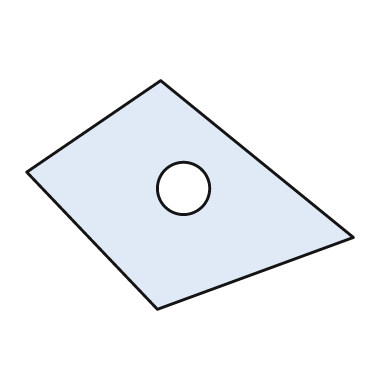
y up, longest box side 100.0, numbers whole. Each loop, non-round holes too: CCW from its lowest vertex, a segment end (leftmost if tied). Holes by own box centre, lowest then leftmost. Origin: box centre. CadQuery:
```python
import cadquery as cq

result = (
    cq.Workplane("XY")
    .moveTo(-10.0, -35.0)
    .lineTo(50.0, -13.0)
    .lineTo(-9.0, 35.0)
    .lineTo(-50.0, 7.0)
    .close()
    .moveTo(-2.0, 2.0)
    .circle(8.0)
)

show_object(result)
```